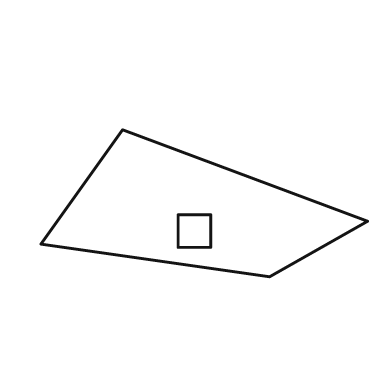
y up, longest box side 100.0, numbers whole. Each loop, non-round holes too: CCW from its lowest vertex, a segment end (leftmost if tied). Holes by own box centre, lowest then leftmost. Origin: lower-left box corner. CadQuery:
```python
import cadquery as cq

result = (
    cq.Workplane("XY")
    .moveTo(70.0, 0.0)
    .lineTo(100.0, 17.0)
    .lineTo(25.0, 45.0)
    .lineTo(0.0, 10.0)
    .close()
    .moveTo(42.0, 9.0)
    .lineTo(52.0, 9.0)
    .lineTo(52.0, 19.0)
    .lineTo(42.0, 19.0)
    .close()
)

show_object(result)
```